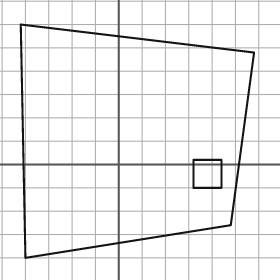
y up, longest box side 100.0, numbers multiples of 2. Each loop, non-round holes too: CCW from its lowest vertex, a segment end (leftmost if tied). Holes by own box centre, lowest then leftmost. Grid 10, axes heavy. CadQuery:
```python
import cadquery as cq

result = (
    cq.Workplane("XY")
    .moveTo(-40.0, -40.0)
    .lineTo(48.0, -26.0)
    .lineTo(58.0, 48.0)
    .lineTo(-42.0, 60.0)
    .close()
    .moveTo(32.0, -10.0)
    .lineTo(44.0, -10.0)
    .lineTo(44.0, 2.0)
    .lineTo(32.0, 2.0)
    .close()
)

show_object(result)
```